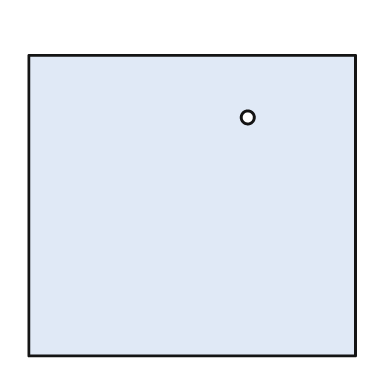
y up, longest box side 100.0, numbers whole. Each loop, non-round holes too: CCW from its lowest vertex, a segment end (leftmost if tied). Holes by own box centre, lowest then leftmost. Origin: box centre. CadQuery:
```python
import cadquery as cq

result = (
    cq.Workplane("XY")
    .moveTo(-50.0, -46.0)
    .lineTo(50.0, -46.0)
    .lineTo(50.0, 46.0)
    .lineTo(-50.0, 46.0)
    .close()
    .moveTo(17.0, 27.0)
    .circle(2.0)
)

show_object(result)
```